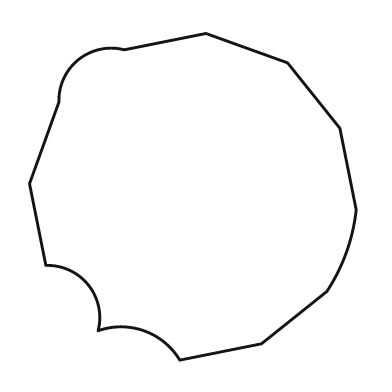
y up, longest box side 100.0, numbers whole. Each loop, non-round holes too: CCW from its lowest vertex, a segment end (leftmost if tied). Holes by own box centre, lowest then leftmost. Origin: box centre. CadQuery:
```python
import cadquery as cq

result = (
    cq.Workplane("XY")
    .moveTo(-4.0, -50.0)
    .lineTo(21.0, -45.0)
    .lineTo(41.0, -29.0)
    .threePointArc((47.0, -17.0), (50.0, -4.0))
    .lineTo(45.0, 21.0)
    .lineTo(29.0, 41.0)
    .lineTo(4.0, 50.0)
    .lineTo(-21.0, 45.0)
    .threePointArc((-35.0, 42.0), (-41.0, 29.0))
    .lineTo(-50.0, 4.0)
    .lineTo(-45.0, -21.0)
    .threePointArc((-32.0, -27.0), (-29.0, -41.0))
    .threePointArc((-15.0, -41.0), (-4.0, -50.0))
    .close()
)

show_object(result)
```